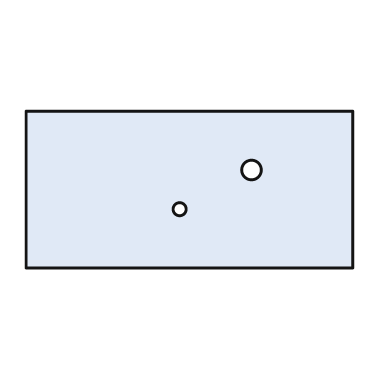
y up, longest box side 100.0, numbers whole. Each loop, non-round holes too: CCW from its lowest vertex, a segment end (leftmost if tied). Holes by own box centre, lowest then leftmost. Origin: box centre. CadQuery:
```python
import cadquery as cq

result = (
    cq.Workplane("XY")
    .moveTo(-50.0, -24.0)
    .lineTo(50.0, -24.0)
    .lineTo(50.0, 24.0)
    .lineTo(-50.0, 24.0)
    .close()
    .moveTo(-3.0, -6.0)
    .circle(2.0)
    .moveTo(19.0, 6.0)
    .circle(3.0)
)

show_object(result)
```